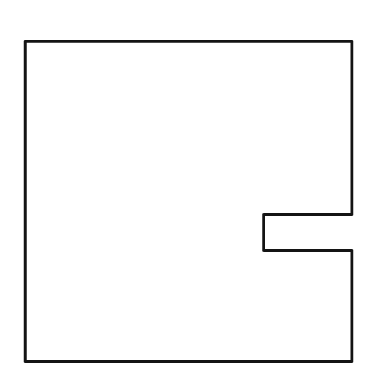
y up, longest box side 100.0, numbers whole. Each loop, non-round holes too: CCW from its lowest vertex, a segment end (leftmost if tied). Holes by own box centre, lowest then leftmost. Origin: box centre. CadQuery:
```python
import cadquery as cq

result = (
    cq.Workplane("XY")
    .moveTo(-50.0, -49.0)
    .lineTo(50.0, -49.0)
    .lineTo(50.0, -15.0)
    .lineTo(23.0, -15.0)
    .lineTo(23.0, -4.0)
    .lineTo(50.0, -4.0)
    .lineTo(50.0, 49.0)
    .lineTo(-50.0, 49.0)
    .close()
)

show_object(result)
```